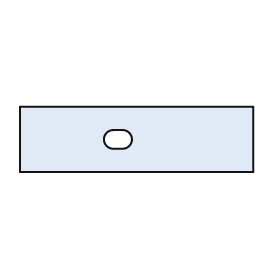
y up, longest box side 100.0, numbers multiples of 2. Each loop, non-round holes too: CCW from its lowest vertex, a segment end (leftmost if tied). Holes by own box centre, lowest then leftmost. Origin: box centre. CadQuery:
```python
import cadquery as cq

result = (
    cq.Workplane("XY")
    .moveTo(-50.0, -14.0)
    .lineTo(50.0, -14.0)
    .lineTo(50.0, 14.0)
    .lineTo(-50.0, 14.0)
    .close()
    .moveTo(-10.0, -4.0)
    .lineTo(-6.0, -4.0)
    .threePointArc((-2.0, 0.0), (-6.0, 4.0))
    .lineTo(-10.0, 4.0)
    .threePointArc((-14.0, 0.0), (-10.0, -4.0))
    .close()
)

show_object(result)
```